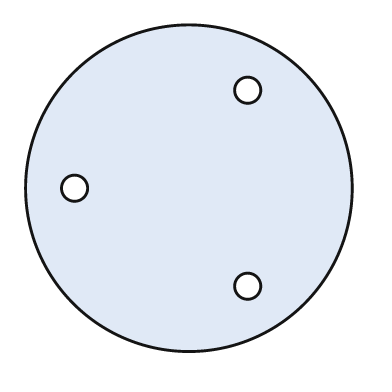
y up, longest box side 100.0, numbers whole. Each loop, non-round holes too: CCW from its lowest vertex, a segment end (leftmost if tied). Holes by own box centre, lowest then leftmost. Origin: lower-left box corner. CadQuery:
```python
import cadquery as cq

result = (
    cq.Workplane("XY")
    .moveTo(50.0, 50.0)
    .circle(50.0)
    .moveTo(68.0, 20.0)
    .circle(4.0)
    .moveTo(15.0, 50.0)
    .circle(4.0)
    .moveTo(68.0, 80.0)
    .circle(4.0)
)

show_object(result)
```